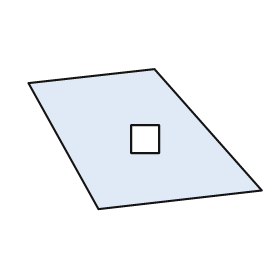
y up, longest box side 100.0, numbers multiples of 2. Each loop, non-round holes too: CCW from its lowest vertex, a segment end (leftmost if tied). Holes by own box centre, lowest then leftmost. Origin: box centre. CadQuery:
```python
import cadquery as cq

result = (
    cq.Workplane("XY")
    .moveTo(-20.0, -30.0)
    .lineTo(50.0, -22.0)
    .lineTo(4.0, 30.0)
    .lineTo(-50.0, 24.0)
    .close()
    .moveTo(-6.0, -6.0)
    .lineTo(6.0, -6.0)
    .lineTo(6.0, 6.0)
    .lineTo(-6.0, 6.0)
    .close()
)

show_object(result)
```